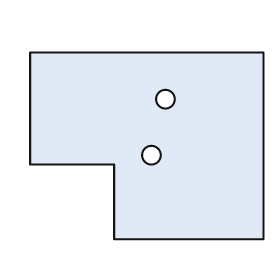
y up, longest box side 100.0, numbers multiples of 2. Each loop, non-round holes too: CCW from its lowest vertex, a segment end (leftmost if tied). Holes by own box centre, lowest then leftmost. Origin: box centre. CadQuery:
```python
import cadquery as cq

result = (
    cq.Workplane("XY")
    .moveTo(-14.0, -40.0)
    .lineTo(50.0, -40.0)
    .lineTo(50.0, 40.0)
    .lineTo(-50.0, 40.0)
    .lineTo(-50.0, -8.0)
    .lineTo(-14.0, -8.0)
    .close()
    .moveTo(2.0, -4.0)
    .circle(4.0)
    .moveTo(8.0, 20.0)
    .circle(4.0)
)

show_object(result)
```